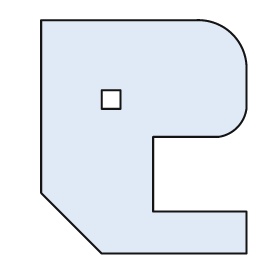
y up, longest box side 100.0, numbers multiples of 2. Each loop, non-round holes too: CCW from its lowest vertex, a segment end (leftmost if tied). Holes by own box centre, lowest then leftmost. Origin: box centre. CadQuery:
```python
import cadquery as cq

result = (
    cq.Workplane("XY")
    .moveTo(-18.0, -50.0)
    .lineTo(44.0, -50.0)
    .lineTo(44.0, -32.0)
    .lineTo(4.0, -32.0)
    .lineTo(4.0, 0.0)
    .lineTo(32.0, 0.0)
    .threePointArc((40.0, 4.0), (44.0, 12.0))
    .lineTo(44.0, 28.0)
    .threePointArc((38.0, 44.0), (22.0, 50.0))
    .lineTo(-44.0, 50.0)
    .lineTo(-44.0, -24.0)
    .close()
    .moveTo(-18.0, 12.0)
    .lineTo(-10.0, 12.0)
    .lineTo(-10.0, 20.0)
    .lineTo(-18.0, 20.0)
    .close()
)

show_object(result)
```